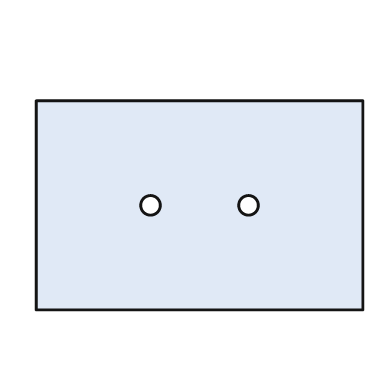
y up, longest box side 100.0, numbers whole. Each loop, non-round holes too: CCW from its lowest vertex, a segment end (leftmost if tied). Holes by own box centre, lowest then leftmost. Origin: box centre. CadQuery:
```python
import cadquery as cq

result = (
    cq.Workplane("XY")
    .moveTo(-50.0, -32.0)
    .lineTo(50.0, -32.0)
    .lineTo(50.0, 32.0)
    .lineTo(-50.0, 32.0)
    .close()
    .moveTo(-15.0, 0.0)
    .circle(3.0)
    .moveTo(15.0, 0.0)
    .circle(3.0)
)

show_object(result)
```